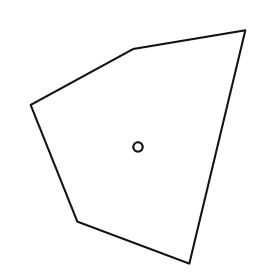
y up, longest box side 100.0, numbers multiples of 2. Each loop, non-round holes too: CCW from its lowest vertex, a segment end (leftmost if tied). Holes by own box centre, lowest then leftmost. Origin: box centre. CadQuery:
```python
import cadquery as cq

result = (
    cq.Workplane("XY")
    .moveTo(22.0, -50.0)
    .lineTo(46.0, 50.0)
    .lineTo(-2.0, 42.0)
    .lineTo(-46.0, 18.0)
    .lineTo(-26.0, -32.0)
    .close()
    .moveTo(0.0, 0.0)
    .circle(2.0)
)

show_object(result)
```